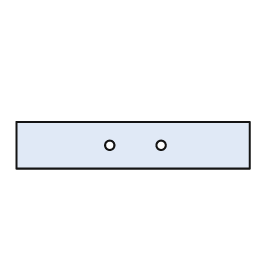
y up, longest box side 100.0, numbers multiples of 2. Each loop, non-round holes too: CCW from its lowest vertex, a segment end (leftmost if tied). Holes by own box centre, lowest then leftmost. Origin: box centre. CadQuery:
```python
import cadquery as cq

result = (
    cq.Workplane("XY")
    .moveTo(-50.0, -10.0)
    .lineTo(50.0, -10.0)
    .lineTo(50.0, 10.0)
    .lineTo(-50.0, 10.0)
    .close()
    .moveTo(-10.0, 0.0)
    .circle(2.0)
    .moveTo(12.0, 0.0)
    .circle(2.0)
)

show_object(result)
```